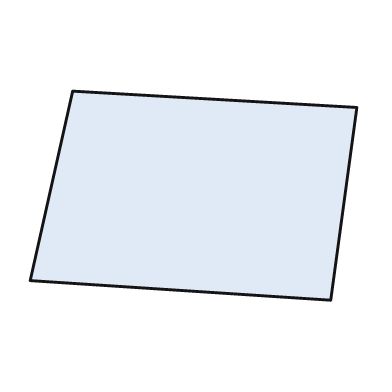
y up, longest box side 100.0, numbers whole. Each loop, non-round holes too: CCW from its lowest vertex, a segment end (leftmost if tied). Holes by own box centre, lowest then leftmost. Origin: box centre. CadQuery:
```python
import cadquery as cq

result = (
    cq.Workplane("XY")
    .moveTo(42.0, -32.0)
    .lineTo(50.0, 27.0)
    .lineTo(-37.0, 32.0)
    .lineTo(-50.0, -26.0)
    .close()
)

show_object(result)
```